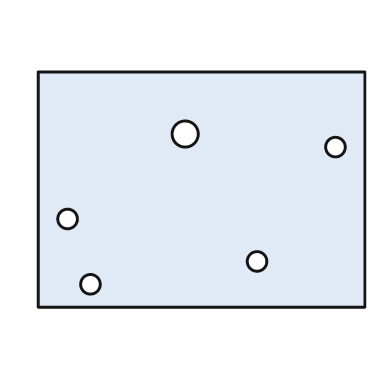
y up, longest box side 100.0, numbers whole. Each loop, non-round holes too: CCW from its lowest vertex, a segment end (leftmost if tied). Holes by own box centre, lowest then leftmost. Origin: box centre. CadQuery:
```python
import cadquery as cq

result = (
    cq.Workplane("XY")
    .moveTo(-50.0, -36.0)
    .lineTo(50.0, -36.0)
    .lineTo(50.0, 36.0)
    .lineTo(-50.0, 36.0)
    .close()
    .moveTo(-34.0, -29.0)
    .circle(3.0)
    .moveTo(17.0, -22.0)
    .circle(3.0)
    .moveTo(-41.0, -9.0)
    .circle(3.0)
    .moveTo(41.0, 13.0)
    .circle(3.0)
    .moveTo(-5.0, 17.0)
    .circle(4.0)
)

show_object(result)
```